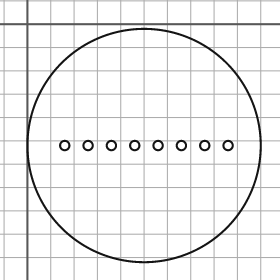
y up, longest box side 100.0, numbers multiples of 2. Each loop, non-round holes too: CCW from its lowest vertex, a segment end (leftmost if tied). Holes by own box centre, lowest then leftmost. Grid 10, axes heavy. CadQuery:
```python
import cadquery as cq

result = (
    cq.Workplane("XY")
    .moveTo(50.0, -52.0)
    .circle(50.0)
    .moveTo(16.0, -52.0)
    .circle(2.0)
    .moveTo(26.0, -52.0)
    .circle(2.0)
    .moveTo(36.0, -52.0)
    .circle(2.0)
    .moveTo(46.0, -52.0)
    .circle(2.0)
    .moveTo(56.0, -52.0)
    .circle(2.0)
    .moveTo(66.0, -52.0)
    .circle(2.0)
    .moveTo(76.0, -52.0)
    .circle(2.0)
    .moveTo(86.0, -52.0)
    .circle(2.0)
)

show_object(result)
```